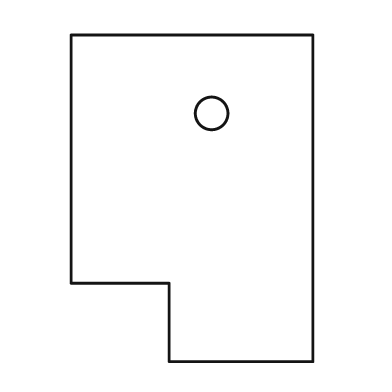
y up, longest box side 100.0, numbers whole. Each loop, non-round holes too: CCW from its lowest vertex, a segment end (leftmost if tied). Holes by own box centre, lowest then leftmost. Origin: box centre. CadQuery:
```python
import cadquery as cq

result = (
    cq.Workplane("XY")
    .moveTo(-7.0, -50.0)
    .lineTo(37.0, -50.0)
    .lineTo(37.0, 50.0)
    .lineTo(-37.0, 50.0)
    .lineTo(-37.0, -26.0)
    .lineTo(-7.0, -26.0)
    .close()
    .moveTo(6.0, 26.0)
    .circle(5.0)
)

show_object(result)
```